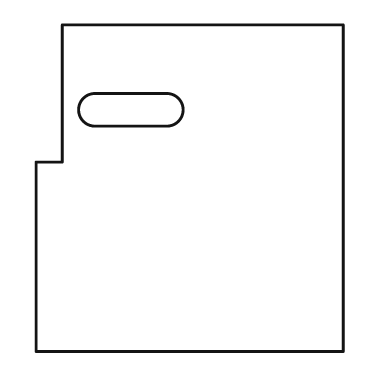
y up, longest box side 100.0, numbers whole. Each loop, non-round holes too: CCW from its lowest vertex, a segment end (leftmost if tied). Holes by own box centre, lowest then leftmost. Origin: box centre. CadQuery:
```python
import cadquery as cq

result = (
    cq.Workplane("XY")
    .moveTo(-47.0, -50.0)
    .lineTo(47.0, -50.0)
    .lineTo(47.0, 50.0)
    .lineTo(-39.0, 50.0)
    .lineTo(-39.0, 8.0)
    .lineTo(-47.0, 8.0)
    .close()
    .moveTo(-29.0, 19.0)
    .lineTo(-7.0, 19.0)
    .threePointArc((-2.0, 24.0), (-7.0, 29.0))
    .lineTo(-29.0, 29.0)
    .threePointArc((-34.0, 24.0), (-29.0, 19.0))
    .close()
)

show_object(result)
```